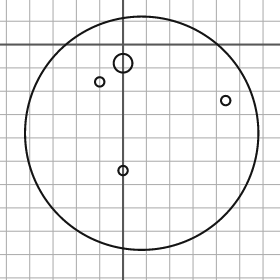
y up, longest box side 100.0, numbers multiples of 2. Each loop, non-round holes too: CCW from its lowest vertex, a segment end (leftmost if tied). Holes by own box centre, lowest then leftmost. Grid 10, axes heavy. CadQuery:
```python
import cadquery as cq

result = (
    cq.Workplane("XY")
    .moveTo(8.0, -38.0)
    .circle(50.0)
    .moveTo(0.0, -54.0)
    .circle(2.0)
    .moveTo(44.0, -24.0)
    .circle(2.0)
    .moveTo(-10.0, -16.0)
    .circle(2.0)
    .moveTo(0.0, -8.0)
    .circle(4.0)
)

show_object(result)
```